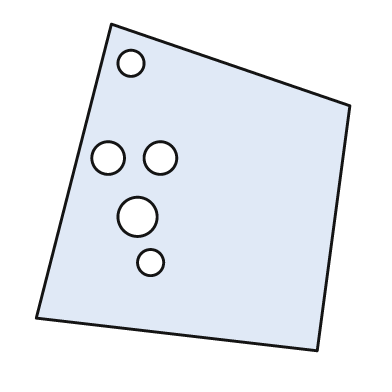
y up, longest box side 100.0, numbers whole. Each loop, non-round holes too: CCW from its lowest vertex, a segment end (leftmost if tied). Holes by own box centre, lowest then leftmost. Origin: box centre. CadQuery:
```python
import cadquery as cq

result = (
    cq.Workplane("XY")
    .moveTo(38.0, -50.0)
    .lineTo(48.0, 25.0)
    .lineTo(-25.0, 50.0)
    .lineTo(-48.0, -40.0)
    .close()
    .moveTo(-13.0, -23.0)
    .circle(4.0)
    .moveTo(-17.0, -9.0)
    .circle(6.0)
    .moveTo(-26.0, 9.0)
    .circle(5.0)
    .moveTo(-10.0, 9.0)
    .circle(5.0)
    .moveTo(-19.0, 38.0)
    .circle(4.0)
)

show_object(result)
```